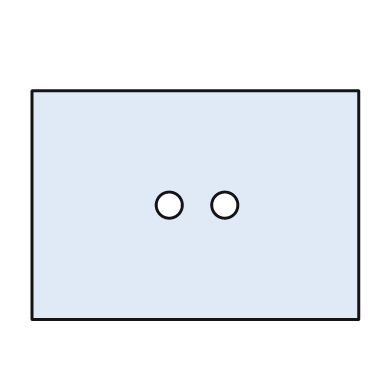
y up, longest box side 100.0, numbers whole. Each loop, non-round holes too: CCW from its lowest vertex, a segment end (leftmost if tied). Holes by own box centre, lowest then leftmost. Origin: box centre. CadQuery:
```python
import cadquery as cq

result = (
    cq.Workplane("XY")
    .moveTo(-50.0, -35.0)
    .lineTo(50.0, -35.0)
    .lineTo(50.0, 35.0)
    .lineTo(-50.0, 35.0)
    .close()
    .moveTo(-8.0, 0.0)
    .circle(4.0)
    .moveTo(9.0, 0.0)
    .circle(4.0)
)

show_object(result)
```